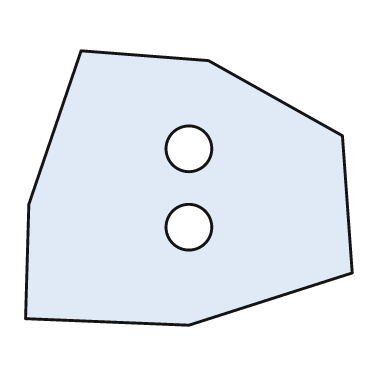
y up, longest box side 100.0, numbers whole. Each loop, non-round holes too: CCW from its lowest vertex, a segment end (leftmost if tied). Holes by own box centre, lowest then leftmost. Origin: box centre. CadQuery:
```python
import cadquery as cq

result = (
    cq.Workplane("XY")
    .moveTo(0.0, -42.0)
    .lineTo(50.0, -26.0)
    .lineTo(47.0, 16.0)
    .lineTo(6.0, 39.0)
    .lineTo(-33.0, 42.0)
    .lineTo(-49.0, -5.0)
    .lineTo(-50.0, -40.0)
    .close()
    .moveTo(0.0, -12.0)
    .circle(7.0)
    .moveTo(0.0, 12.0)
    .circle(7.0)
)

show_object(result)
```